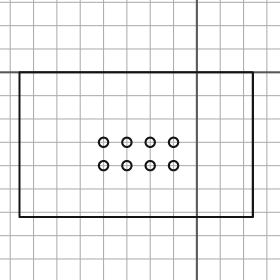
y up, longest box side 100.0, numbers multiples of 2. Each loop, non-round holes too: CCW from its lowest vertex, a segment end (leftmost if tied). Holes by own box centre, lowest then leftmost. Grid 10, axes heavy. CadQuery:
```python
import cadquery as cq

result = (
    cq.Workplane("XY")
    .moveTo(-76.0, -62.0)
    .lineTo(24.0, -62.0)
    .lineTo(24.0, 0.0)
    .lineTo(-76.0, 0.0)
    .close()
    .moveTo(-40.0, -40.0)
    .circle(2.0)
    .moveTo(-30.0, -40.0)
    .circle(2.0)
    .moveTo(-20.0, -40.0)
    .circle(2.0)
    .moveTo(-10.0, -40.0)
    .circle(2.0)
    .moveTo(-40.0, -30.0)
    .circle(2.0)
    .moveTo(-30.0, -30.0)
    .circle(2.0)
    .moveTo(-20.0, -30.0)
    .circle(2.0)
    .moveTo(-10.0, -30.0)
    .circle(2.0)
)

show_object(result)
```